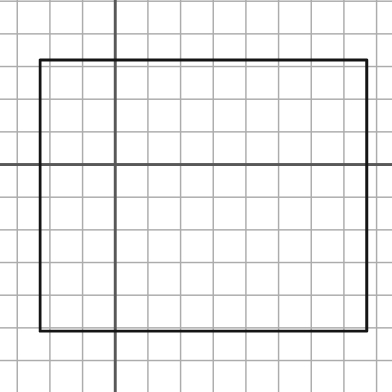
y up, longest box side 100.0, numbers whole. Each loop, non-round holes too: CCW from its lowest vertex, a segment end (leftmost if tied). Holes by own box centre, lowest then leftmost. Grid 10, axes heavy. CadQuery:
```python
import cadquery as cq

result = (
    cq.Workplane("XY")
    .moveTo(-23.0, -51.0)
    .lineTo(77.0, -51.0)
    .lineTo(77.0, 32.0)
    .lineTo(-23.0, 32.0)
    .close()
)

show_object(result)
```